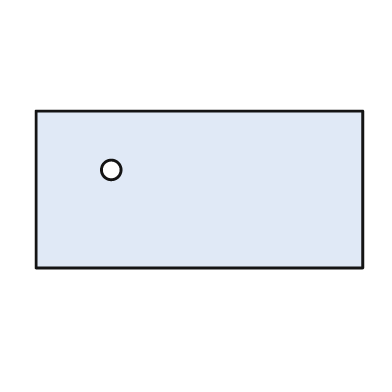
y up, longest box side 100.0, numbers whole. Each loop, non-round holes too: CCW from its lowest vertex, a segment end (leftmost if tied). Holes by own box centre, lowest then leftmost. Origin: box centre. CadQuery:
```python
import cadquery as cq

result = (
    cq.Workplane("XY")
    .moveTo(-50.0, -24.0)
    .lineTo(50.0, -24.0)
    .lineTo(50.0, 24.0)
    .lineTo(-50.0, 24.0)
    .close()
    .moveTo(-27.0, 6.0)
    .circle(3.0)
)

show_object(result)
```